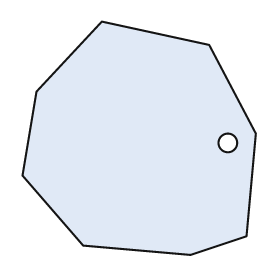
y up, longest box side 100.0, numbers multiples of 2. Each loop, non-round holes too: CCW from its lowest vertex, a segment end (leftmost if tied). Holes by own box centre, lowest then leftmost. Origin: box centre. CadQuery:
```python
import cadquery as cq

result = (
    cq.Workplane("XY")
    .moveTo(22.0, -50.0)
    .lineTo(46.0, -42.0)
    .lineTo(50.0, 2.0)
    .lineTo(30.0, 40.0)
    .lineTo(-16.0, 50.0)
    .lineTo(-44.0, 20.0)
    .lineTo(-50.0, -16.0)
    .lineTo(-24.0, -46.0)
    .close()
    .moveTo(38.0, -2.0)
    .circle(4.0)
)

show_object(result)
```